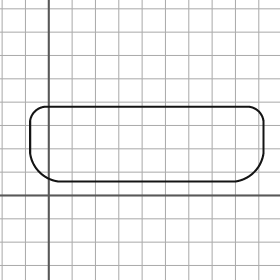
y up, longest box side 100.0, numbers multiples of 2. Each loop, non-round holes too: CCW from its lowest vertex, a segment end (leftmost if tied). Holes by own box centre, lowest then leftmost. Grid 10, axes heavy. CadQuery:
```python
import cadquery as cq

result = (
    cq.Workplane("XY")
    .moveTo(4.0, 6.0)
    .lineTo(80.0, 6.0)
    .threePointArc((88.0, 10.0), (92.0, 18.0))
    .lineTo(92.0, 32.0)
    .threePointArc((90.0, 36.0), (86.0, 38.0))
    .lineTo(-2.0, 38.0)
    .threePointArc((-6.0, 36.0), (-8.0, 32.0))
    .lineTo(-8.0, 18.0)
    .threePointArc((-4.0, 10.0), (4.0, 6.0))
    .close()
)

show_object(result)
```